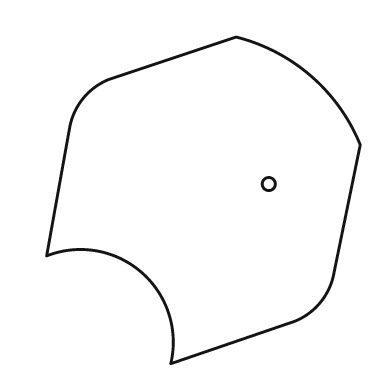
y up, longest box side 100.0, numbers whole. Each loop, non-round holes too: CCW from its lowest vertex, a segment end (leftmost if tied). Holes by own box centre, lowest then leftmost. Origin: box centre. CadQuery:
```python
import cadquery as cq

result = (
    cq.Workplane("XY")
    .moveTo(-10.0, -50.0)
    .lineTo(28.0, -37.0)
    .threePointArc((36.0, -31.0), (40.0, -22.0))
    .lineTo(48.0, 17.0)
    .threePointArc((33.0, 38.0), (10.0, 50.0))
    .lineTo(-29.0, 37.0)
    .threePointArc((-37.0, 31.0), (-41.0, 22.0))
    .lineTo(-48.0, -17.0)
    .threePointArc((-19.0, -22.0), (-10.0, -50.0))
    .close()
    .moveTo(20.0, 5.0)
    .circle(2.0)
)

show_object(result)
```